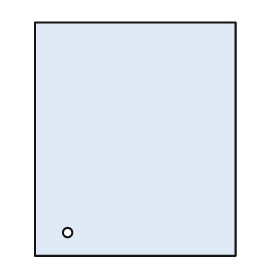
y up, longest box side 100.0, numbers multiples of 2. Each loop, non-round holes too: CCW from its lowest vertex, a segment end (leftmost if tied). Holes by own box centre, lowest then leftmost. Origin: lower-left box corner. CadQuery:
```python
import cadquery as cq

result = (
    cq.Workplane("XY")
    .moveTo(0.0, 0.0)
    .lineTo(86.0, 0.0)
    .lineTo(86.0, 100.0)
    .lineTo(0.0, 100.0)
    .close()
    .moveTo(14.0, 10.0)
    .circle(2.0)
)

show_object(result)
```